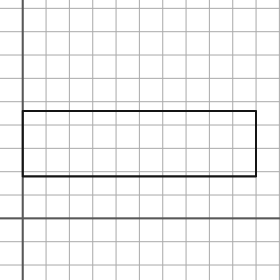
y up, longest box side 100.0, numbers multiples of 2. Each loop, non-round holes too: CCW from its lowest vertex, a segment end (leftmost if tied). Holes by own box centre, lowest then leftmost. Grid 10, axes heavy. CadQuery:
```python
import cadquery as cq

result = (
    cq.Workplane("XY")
    .moveTo(0.0, 18.0)
    .lineTo(100.0, 18.0)
    .lineTo(100.0, 46.0)
    .lineTo(0.0, 46.0)
    .close()
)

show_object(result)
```